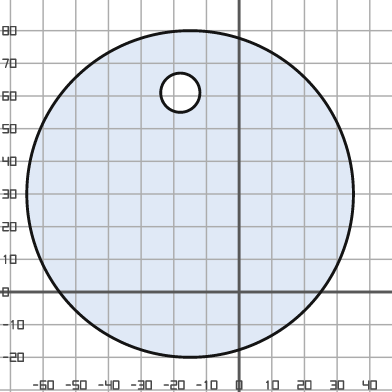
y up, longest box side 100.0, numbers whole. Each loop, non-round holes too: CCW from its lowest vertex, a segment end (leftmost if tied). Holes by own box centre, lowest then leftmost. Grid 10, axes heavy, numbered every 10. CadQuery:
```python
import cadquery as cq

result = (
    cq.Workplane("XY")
    .moveTo(-15.0, 30.0)
    .circle(50.0)
    .moveTo(-18.0, 61.0)
    .circle(6.0)
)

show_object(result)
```